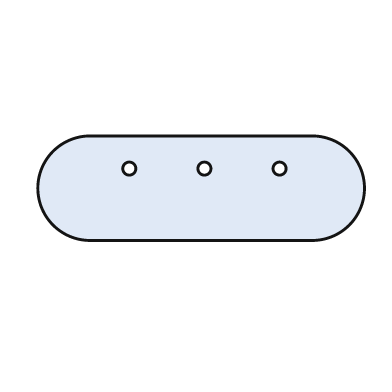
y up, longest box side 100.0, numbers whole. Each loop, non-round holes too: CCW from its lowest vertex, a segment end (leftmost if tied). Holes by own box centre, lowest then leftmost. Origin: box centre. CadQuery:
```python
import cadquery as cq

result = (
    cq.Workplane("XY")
    .moveTo(-34.0, -16.0)
    .lineTo(34.0, -16.0)
    .threePointArc((50.0, 0.0), (34.0, 16.0))
    .lineTo(-34.0, 16.0)
    .threePointArc((-50.0, 0.0), (-34.0, -16.0))
    .close()
    .moveTo(-22.0, 6.0)
    .circle(2.0)
    .moveTo(1.0, 6.0)
    .circle(2.0)
    .moveTo(24.0, 6.0)
    .circle(2.0)
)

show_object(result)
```